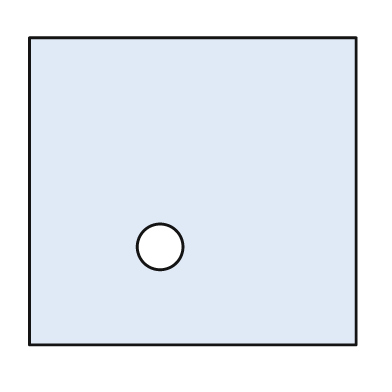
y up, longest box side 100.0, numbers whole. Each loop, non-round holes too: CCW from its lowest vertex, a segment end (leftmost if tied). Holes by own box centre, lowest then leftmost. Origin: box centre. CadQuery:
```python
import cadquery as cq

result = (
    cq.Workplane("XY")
    .moveTo(-50.0, -47.0)
    .lineTo(50.0, -47.0)
    .lineTo(50.0, 47.0)
    .lineTo(-50.0, 47.0)
    .close()
    .moveTo(-10.0, -17.0)
    .circle(7.0)
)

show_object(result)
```